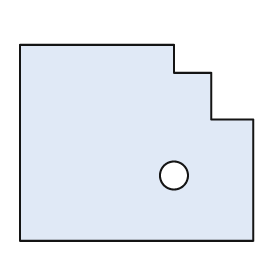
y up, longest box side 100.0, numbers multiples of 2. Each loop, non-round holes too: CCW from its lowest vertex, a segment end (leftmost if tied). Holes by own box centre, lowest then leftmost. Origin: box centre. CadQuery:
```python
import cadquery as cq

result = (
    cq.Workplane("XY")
    .moveTo(-50.0, -42.0)
    .lineTo(50.0, -42.0)
    .lineTo(50.0, 10.0)
    .lineTo(32.0, 10.0)
    .lineTo(32.0, 30.0)
    .lineTo(16.0, 30.0)
    .lineTo(16.0, 42.0)
    .lineTo(-50.0, 42.0)
    .close()
    .moveTo(16.0, -14.0)
    .circle(6.0)
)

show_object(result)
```